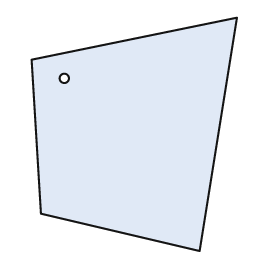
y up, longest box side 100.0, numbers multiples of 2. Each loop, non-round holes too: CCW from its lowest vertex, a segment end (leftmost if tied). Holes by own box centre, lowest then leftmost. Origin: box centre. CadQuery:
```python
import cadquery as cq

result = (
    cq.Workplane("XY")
    .moveTo(28.0, -50.0)
    .lineTo(44.0, 50.0)
    .lineTo(-44.0, 32.0)
    .lineTo(-40.0, -34.0)
    .close()
    .moveTo(-30.0, 24.0)
    .circle(2.0)
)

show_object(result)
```